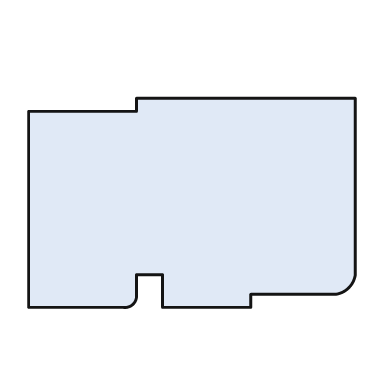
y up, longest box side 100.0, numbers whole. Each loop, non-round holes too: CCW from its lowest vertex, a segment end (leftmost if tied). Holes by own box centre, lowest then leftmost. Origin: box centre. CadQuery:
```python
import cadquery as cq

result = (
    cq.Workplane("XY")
    .moveTo(-50.0, -32.0)
    .lineTo(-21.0, -32.0)
    .threePointArc((-18.0, -31.0), (-17.0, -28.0))
    .lineTo(-17.0, -22.0)
    .lineTo(-9.0, -22.0)
    .lineTo(-9.0, -32.0)
    .lineTo(18.0, -32.0)
    .lineTo(18.0, -28.0)
    .lineTo(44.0, -28.0)
    .threePointArc((48.0, -26.0), (50.0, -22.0))
    .lineTo(50.0, 32.0)
    .lineTo(-17.0, 32.0)
    .lineTo(-17.0, 28.0)
    .lineTo(-50.0, 28.0)
    .close()
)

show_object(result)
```